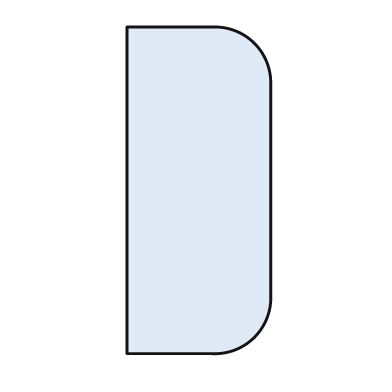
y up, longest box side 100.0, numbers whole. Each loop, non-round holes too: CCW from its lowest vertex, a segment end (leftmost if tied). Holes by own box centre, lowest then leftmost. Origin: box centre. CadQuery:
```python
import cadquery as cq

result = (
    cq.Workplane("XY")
    .moveTo(-22.0, -50.0)
    .lineTo(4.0, -50.0)
    .threePointArc((17.0, -45.0), (22.0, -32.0))
    .lineTo(22.0, 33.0)
    .threePointArc((17.0, 45.0), (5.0, 50.0))
    .lineTo(-22.0, 50.0)
    .close()
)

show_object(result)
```